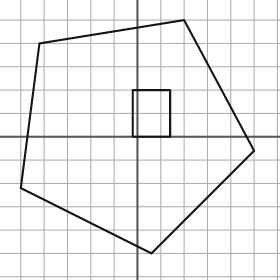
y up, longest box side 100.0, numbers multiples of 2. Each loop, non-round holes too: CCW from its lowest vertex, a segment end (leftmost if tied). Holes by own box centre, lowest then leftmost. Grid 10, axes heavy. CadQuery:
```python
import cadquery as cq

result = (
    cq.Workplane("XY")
    .moveTo(6.0, -50.0)
    .lineTo(50.0, -6.0)
    .lineTo(20.0, 50.0)
    .lineTo(-42.0, 40.0)
    .lineTo(-50.0, -22.0)
    .close()
    .moveTo(-2.0, 0.0)
    .lineTo(14.0, 0.0)
    .lineTo(14.0, 20.0)
    .lineTo(-2.0, 20.0)
    .close()
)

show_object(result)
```